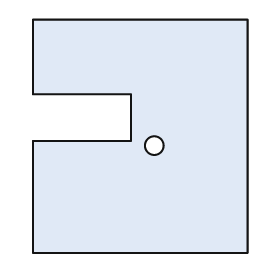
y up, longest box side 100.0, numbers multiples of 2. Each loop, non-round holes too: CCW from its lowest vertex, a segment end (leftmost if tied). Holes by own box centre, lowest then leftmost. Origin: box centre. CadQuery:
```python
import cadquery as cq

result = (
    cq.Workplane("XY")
    .moveTo(-46.0, -50.0)
    .lineTo(46.0, -50.0)
    .lineTo(46.0, 50.0)
    .lineTo(-46.0, 50.0)
    .lineTo(-46.0, 18.0)
    .lineTo(-4.0, 18.0)
    .lineTo(-4.0, -2.0)
    .lineTo(-46.0, -2.0)
    .close()
    .moveTo(6.0, -4.0)
    .circle(4.0)
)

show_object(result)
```